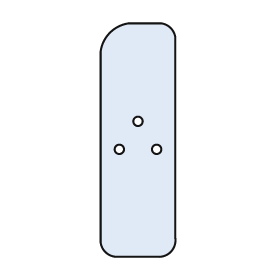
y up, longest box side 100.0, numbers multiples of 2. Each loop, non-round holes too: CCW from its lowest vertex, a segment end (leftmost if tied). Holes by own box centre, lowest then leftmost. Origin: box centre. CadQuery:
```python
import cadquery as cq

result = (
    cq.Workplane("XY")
    .moveTo(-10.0, -50.0)
    .lineTo(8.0, -50.0)
    .threePointArc((14.0, -48.0), (16.0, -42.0))
    .lineTo(16.0, 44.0)
    .threePointArc((14.0, 48.0), (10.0, 50.0))
    .lineTo(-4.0, 50.0)
    .threePointArc((-12.0, 46.0), (-16.0, 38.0))
    .lineTo(-16.0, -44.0)
    .threePointArc((-14.0, -48.0), (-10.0, -50.0))
    .close()
    .moveTo(-8.0, -4.0)
    .circle(2.0)
    .moveTo(8.0, -4.0)
    .circle(2.0)
    .moveTo(0.0, 8.0)
    .circle(2.0)
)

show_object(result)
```